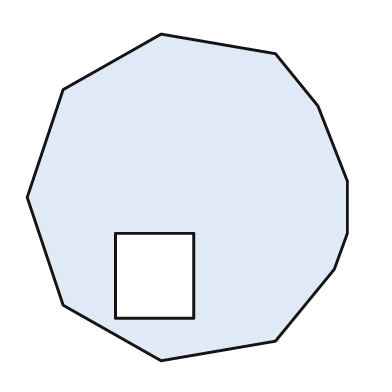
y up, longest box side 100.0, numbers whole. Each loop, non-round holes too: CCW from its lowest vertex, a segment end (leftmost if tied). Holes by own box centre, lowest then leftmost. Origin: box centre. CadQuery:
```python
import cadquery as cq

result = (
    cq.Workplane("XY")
    .moveTo(-8.0, -50.0)
    .lineTo(27.0, -44.0)
    .lineTo(45.0, -22.0)
    .lineTo(49.0, -11.0)
    .lineTo(49.0, 5.0)
    .lineTo(40.0, 28.0)
    .lineTo(27.0, 44.0)
    .lineTo(-8.0, 50.0)
    .lineTo(-38.0, 33.0)
    .lineTo(-49.0, 0.0)
    .lineTo(-38.0, -33.0)
    .close()
    .moveTo(-22.0, -37.0)
    .lineTo(2.0, -37.0)
    .lineTo(2.0, -11.0)
    .lineTo(-22.0, -11.0)
    .close()
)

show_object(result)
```